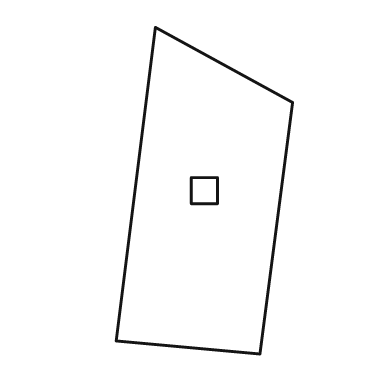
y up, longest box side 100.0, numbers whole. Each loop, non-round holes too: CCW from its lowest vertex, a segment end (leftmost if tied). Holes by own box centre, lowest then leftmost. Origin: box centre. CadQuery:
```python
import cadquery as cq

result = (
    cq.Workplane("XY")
    .moveTo(17.0, -50.0)
    .lineTo(27.0, 27.0)
    .lineTo(-15.0, 50.0)
    .lineTo(-27.0, -46.0)
    .close()
    .moveTo(-4.0, -4.0)
    .lineTo(4.0, -4.0)
    .lineTo(4.0, 4.0)
    .lineTo(-4.0, 4.0)
    .close()
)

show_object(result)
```